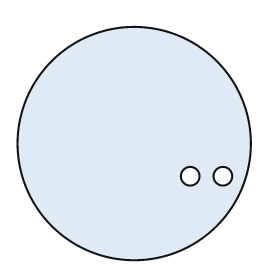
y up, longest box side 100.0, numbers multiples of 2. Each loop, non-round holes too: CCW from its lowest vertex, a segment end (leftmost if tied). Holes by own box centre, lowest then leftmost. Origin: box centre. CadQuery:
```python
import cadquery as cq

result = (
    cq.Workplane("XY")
    .moveTo(0.0, 0.0)
    .circle(50.0)
    .moveTo(24.0, -14.0)
    .circle(4.0)
    .moveTo(38.0, -14.0)
    .circle(4.0)
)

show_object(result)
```